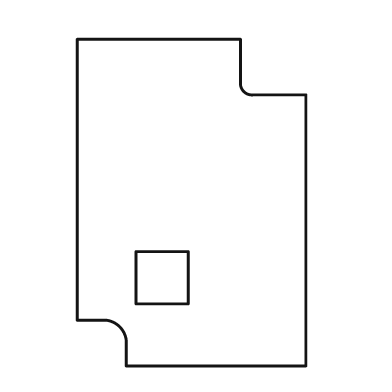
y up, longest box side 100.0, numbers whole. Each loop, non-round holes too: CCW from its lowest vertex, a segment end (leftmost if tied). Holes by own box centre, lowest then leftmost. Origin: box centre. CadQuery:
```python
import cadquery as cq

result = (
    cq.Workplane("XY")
    .moveTo(-20.0, -50.0)
    .lineTo(35.0, -50.0)
    .lineTo(35.0, 33.0)
    .lineTo(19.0, 33.0)
    .threePointArc((16.0, 34.0), (15.0, 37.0))
    .lineTo(15.0, 50.0)
    .lineTo(-35.0, 50.0)
    .lineTo(-35.0, -36.0)
    .lineTo(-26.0, -36.0)
    .threePointArc((-22.0, -38.0), (-20.0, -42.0))
    .close()
    .moveTo(-17.0, -31.0)
    .lineTo(-1.0, -31.0)
    .lineTo(-1.0, -15.0)
    .lineTo(-17.0, -15.0)
    .close()
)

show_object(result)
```